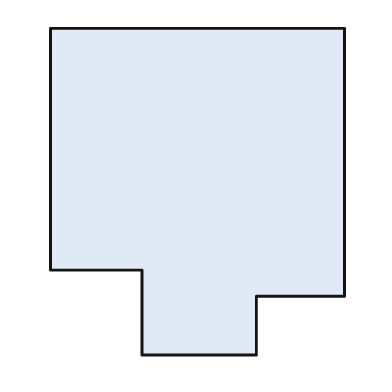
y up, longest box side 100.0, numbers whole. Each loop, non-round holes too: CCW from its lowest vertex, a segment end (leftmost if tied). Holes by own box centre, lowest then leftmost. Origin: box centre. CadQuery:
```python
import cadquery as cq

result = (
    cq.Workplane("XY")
    .moveTo(-17.0, -50.0)
    .lineTo(18.0, -50.0)
    .lineTo(18.0, -32.0)
    .lineTo(45.0, -32.0)
    .lineTo(45.0, 50.0)
    .lineTo(-45.0, 50.0)
    .lineTo(-45.0, -24.0)
    .lineTo(-17.0, -24.0)
    .close()
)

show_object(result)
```